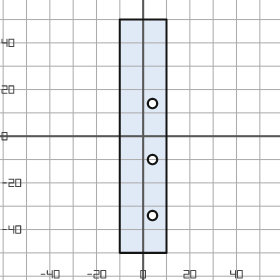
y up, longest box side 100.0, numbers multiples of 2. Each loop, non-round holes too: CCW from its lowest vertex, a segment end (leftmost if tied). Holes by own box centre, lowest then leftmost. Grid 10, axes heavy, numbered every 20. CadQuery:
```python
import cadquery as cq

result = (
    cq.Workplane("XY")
    .moveTo(-10.0, -50.0)
    .lineTo(10.0, -50.0)
    .lineTo(10.0, 50.0)
    .lineTo(-10.0, 50.0)
    .close()
    .moveTo(4.0, -34.0)
    .circle(2.0)
    .moveTo(4.0, -10.0)
    .circle(2.0)
    .moveTo(4.0, 14.0)
    .circle(2.0)
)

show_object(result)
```